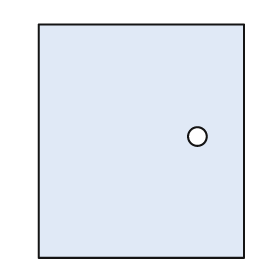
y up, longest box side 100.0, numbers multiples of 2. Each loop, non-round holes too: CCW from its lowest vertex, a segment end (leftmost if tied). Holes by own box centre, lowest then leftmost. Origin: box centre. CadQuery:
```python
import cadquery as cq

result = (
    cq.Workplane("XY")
    .moveTo(-44.0, -50.0)
    .lineTo(44.0, -50.0)
    .lineTo(44.0, 50.0)
    .lineTo(-44.0, 50.0)
    .close()
    .moveTo(24.0, 2.0)
    .circle(4.0)
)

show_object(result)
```